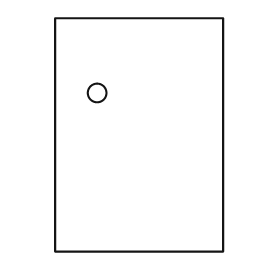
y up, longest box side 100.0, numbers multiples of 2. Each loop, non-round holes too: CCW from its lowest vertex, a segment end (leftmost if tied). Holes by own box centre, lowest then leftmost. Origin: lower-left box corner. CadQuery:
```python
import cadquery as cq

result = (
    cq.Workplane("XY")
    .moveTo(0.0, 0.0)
    .lineTo(72.0, 0.0)
    .lineTo(72.0, 100.0)
    .lineTo(0.0, 100.0)
    .close()
    .moveTo(18.0, 68.0)
    .circle(4.0)
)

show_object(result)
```